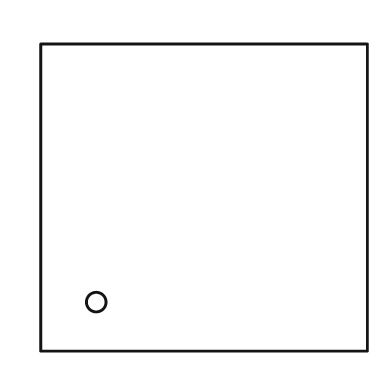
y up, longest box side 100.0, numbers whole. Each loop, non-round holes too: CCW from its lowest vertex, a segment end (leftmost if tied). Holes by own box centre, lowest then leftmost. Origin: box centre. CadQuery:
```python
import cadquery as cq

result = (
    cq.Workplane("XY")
    .moveTo(-50.0, -47.0)
    .lineTo(50.0, -47.0)
    .lineTo(50.0, 47.0)
    .lineTo(-50.0, 47.0)
    .close()
    .moveTo(-33.0, -32.0)
    .circle(3.0)
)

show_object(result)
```